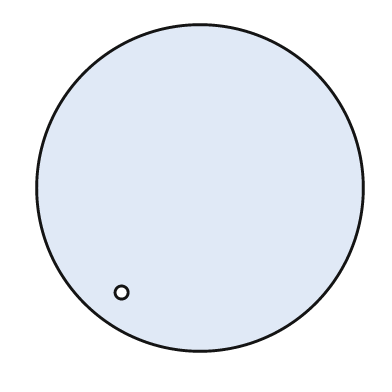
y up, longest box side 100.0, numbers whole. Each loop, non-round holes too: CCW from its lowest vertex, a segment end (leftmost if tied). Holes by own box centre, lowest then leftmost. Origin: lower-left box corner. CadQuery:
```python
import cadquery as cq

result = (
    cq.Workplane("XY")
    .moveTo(50.0, 50.0)
    .circle(50.0)
    .moveTo(26.0, 18.0)
    .circle(2.0)
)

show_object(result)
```